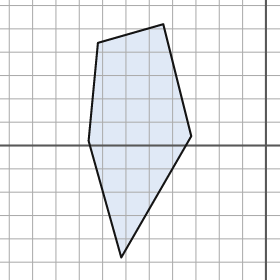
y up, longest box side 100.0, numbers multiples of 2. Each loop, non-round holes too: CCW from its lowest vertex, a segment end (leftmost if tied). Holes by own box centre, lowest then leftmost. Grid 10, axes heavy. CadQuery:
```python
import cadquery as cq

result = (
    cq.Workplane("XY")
    .moveTo(-62.0, -48.0)
    .lineTo(-32.0, 4.0)
    .lineTo(-44.0, 52.0)
    .lineTo(-72.0, 44.0)
    .lineTo(-76.0, 2.0)
    .close()
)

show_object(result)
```